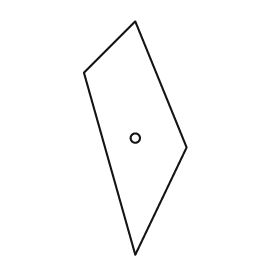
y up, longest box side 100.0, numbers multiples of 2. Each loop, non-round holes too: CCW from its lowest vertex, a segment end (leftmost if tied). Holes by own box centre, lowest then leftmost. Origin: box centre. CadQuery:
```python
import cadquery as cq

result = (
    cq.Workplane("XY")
    .moveTo(0.0, -50.0)
    .lineTo(22.0, -4.0)
    .lineTo(0.0, 50.0)
    .lineTo(-22.0, 28.0)
    .close()
    .moveTo(0.0, 0.0)
    .circle(2.0)
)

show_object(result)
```